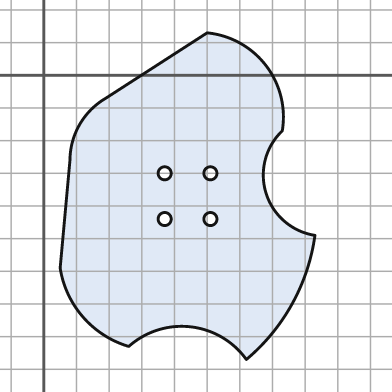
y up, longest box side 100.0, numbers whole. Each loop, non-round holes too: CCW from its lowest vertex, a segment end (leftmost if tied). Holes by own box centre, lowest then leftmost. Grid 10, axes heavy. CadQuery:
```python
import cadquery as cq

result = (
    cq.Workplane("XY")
    .moveTo(62.0, -87.0)
    .threePointArc((76.0, -70.0), (83.0, -49.0))
    .threePointArc((68.0, -36.0), (73.0, -17.0))
    .threePointArc((68.0, 3.0), (50.0, 13.0))
    .lineTo(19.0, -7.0)
    .threePointArc((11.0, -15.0), (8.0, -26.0))
    .lineTo(5.0, -59.0)
    .threePointArc((12.0, -74.0), (26.0, -83.0))
    .threePointArc((45.0, -77.0), (62.0, -87.0))
    .close()
    .moveTo(37.0, -44.0)
    .circle(2.0)
    .moveTo(51.0, -44.0)
    .circle(2.0)
    .moveTo(37.0, -30.0)
    .circle(2.0)
    .moveTo(51.0, -30.0)
    .circle(2.0)
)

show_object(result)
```